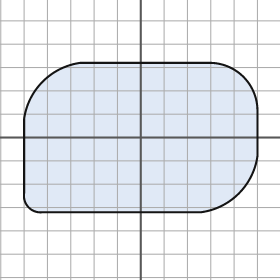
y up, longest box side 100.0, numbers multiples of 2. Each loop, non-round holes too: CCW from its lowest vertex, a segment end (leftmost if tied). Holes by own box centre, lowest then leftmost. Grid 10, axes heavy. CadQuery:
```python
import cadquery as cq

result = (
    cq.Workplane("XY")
    .moveTo(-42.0, -32.0)
    .lineTo(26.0, -32.0)
    .threePointArc((42.0, -24.0), (50.0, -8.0))
    .lineTo(50.0, 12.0)
    .threePointArc((44.0, 26.0), (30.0, 32.0))
    .lineTo(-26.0, 32.0)
    .threePointArc((-42.0, 24.0), (-50.0, 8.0))
    .lineTo(-50.0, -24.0)
    .threePointArc((-48.0, -30.0), (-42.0, -32.0))
    .close()
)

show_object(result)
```